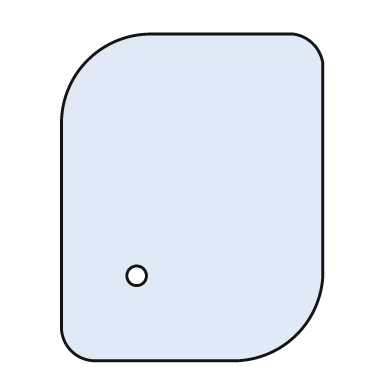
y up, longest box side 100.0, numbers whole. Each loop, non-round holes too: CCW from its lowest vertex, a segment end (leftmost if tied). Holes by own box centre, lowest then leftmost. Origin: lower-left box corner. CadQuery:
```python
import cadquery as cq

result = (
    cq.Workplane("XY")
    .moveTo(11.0, 0.0)
    .lineTo(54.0, 0.0)
    .threePointArc((72.0, 8.0), (80.0, 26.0))
    .lineTo(80.0, 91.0)
    .threePointArc((77.0, 97.0), (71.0, 100.0))
    .lineTo(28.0, 100.0)
    .threePointArc((8.0, 92.0), (0.0, 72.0))
    .lineTo(0.0, 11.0)
    .threePointArc((3.0, 3.0), (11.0, 0.0))
    .close()
    .moveTo(23.0, 26.0)
    .circle(3.0)
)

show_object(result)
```